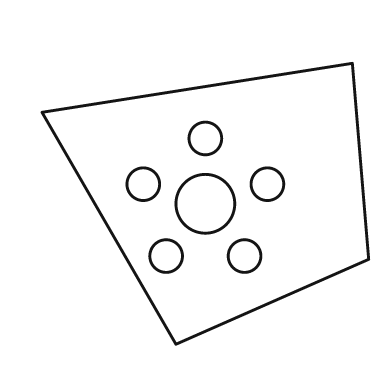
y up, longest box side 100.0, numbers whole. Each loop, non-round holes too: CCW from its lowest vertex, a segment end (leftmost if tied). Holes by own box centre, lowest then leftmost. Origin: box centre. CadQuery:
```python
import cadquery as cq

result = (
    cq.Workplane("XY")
    .moveTo(-9.0, -43.0)
    .lineTo(50.0, -17.0)
    .lineTo(45.0, 43.0)
    .lineTo(-50.0, 28.0)
    .close()
    .moveTo(-12.0, -16.0)
    .circle(5.0)
    .moveTo(12.0, -16.0)
    .circle(5.0)
    .moveTo(0.0, 0.0)
    .circle(9.0)
    .moveTo(-19.0, 6.0)
    .circle(5.0)
    .moveTo(19.0, 6.0)
    .circle(5.0)
    .moveTo(0.0, 20.0)
    .circle(5.0)
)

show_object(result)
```